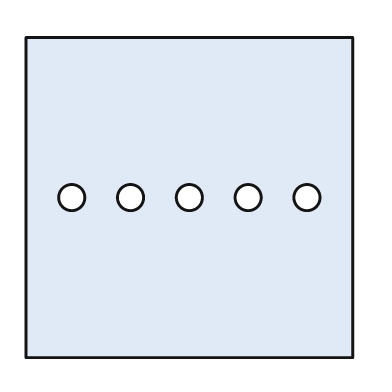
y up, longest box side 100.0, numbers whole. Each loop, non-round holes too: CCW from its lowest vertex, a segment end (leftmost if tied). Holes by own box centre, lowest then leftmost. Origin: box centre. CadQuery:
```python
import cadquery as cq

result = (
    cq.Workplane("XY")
    .moveTo(-50.0, -49.0)
    .lineTo(50.0, -49.0)
    .lineTo(50.0, 49.0)
    .lineTo(-50.0, 49.0)
    .close()
    .moveTo(-36.0, 0.0)
    .circle(4.0)
    .moveTo(-18.0, 0.0)
    .circle(4.0)
    .moveTo(0.0, 0.0)
    .circle(4.0)
    .moveTo(18.0, 0.0)
    .circle(4.0)
    .moveTo(36.0, 0.0)
    .circle(4.0)
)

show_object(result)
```